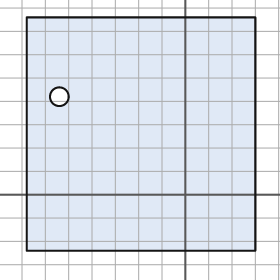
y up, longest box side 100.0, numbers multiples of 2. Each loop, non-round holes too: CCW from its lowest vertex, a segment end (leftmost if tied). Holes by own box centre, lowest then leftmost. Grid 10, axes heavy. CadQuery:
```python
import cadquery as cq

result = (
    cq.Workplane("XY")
    .moveTo(-68.0, -24.0)
    .lineTo(30.0, -24.0)
    .lineTo(30.0, 76.0)
    .lineTo(-68.0, 76.0)
    .close()
    .moveTo(-54.0, 42.0)
    .circle(4.0)
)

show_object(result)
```